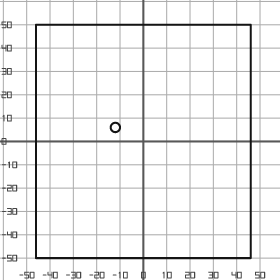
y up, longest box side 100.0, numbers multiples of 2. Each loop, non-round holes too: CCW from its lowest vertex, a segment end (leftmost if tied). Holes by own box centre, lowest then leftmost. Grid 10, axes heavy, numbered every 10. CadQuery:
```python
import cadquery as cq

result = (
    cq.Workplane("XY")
    .moveTo(-46.0, -50.0)
    .lineTo(46.0, -50.0)
    .lineTo(46.0, 50.0)
    .lineTo(-46.0, 50.0)
    .close()
    .moveTo(-12.0, 6.0)
    .circle(2.0)
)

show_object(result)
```